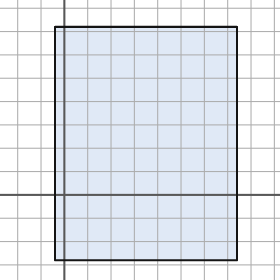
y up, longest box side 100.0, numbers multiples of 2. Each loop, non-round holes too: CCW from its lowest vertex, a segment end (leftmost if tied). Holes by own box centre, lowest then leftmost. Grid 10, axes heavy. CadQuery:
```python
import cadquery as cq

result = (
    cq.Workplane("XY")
    .moveTo(-4.0, -28.0)
    .lineTo(74.0, -28.0)
    .lineTo(74.0, 72.0)
    .lineTo(-4.0, 72.0)
    .close()
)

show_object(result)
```